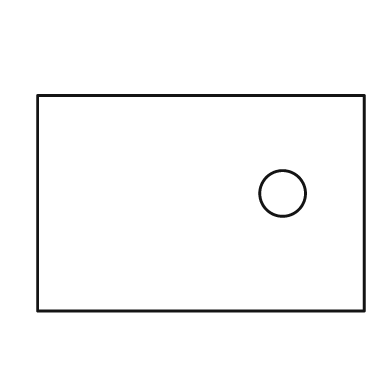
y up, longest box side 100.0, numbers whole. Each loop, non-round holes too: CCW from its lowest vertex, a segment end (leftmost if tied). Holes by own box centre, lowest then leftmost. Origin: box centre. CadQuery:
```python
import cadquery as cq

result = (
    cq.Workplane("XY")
    .moveTo(-50.0, -33.0)
    .lineTo(50.0, -33.0)
    .lineTo(50.0, 33.0)
    .lineTo(-50.0, 33.0)
    .close()
    .moveTo(25.0, 3.0)
    .circle(7.0)
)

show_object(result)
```